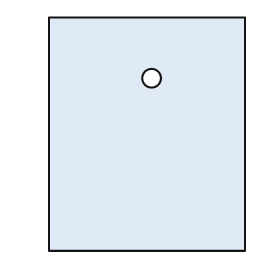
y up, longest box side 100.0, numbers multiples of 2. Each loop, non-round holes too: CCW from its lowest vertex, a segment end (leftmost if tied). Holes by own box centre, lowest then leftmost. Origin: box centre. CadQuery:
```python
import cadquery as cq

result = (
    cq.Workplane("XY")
    .moveTo(-42.0, -50.0)
    .lineTo(42.0, -50.0)
    .lineTo(42.0, 50.0)
    .lineTo(-42.0, 50.0)
    .close()
    .moveTo(2.0, 24.0)
    .circle(4.0)
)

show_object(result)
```